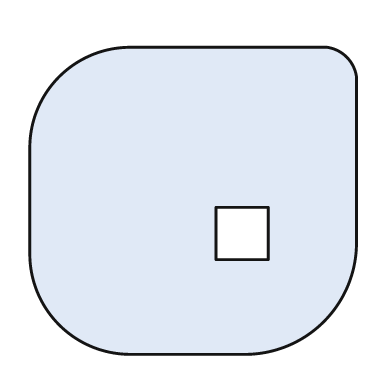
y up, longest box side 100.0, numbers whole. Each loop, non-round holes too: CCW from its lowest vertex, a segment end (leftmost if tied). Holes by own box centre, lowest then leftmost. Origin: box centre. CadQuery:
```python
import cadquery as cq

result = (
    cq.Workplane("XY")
    .moveTo(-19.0, -47.0)
    .lineTo(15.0, -47.0)
    .threePointArc((40.0, -37.0), (50.0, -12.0))
    .lineTo(50.0, 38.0)
    .threePointArc((47.0, 44.0), (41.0, 47.0))
    .lineTo(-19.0, 47.0)
    .threePointArc((-41.0, 38.0), (-50.0, 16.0))
    .lineTo(-50.0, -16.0)
    .threePointArc((-41.0, -38.0), (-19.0, -47.0))
    .close()
    .moveTo(7.0, -18.0)
    .lineTo(23.0, -18.0)
    .lineTo(23.0, -2.0)
    .lineTo(7.0, -2.0)
    .close()
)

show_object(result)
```